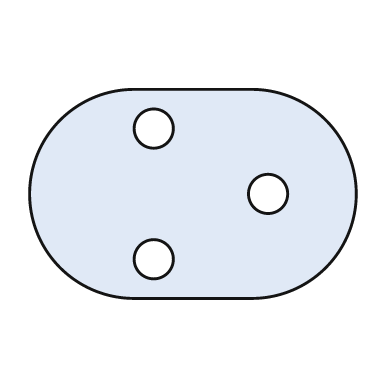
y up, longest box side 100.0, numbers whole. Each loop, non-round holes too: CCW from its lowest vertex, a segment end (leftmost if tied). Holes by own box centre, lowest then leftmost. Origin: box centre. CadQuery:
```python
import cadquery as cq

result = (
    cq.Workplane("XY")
    .moveTo(-18.0, -32.0)
    .lineTo(18.0, -32.0)
    .threePointArc((50.0, 0.0), (18.0, 32.0))
    .lineTo(-18.0, 32.0)
    .threePointArc((-50.0, 0.0), (-18.0, -32.0))
    .close()
    .moveTo(-12.0, -20.0)
    .circle(6.0)
    .moveTo(23.0, 0.0)
    .circle(6.0)
    .moveTo(-12.0, 20.0)
    .circle(6.0)
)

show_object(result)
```